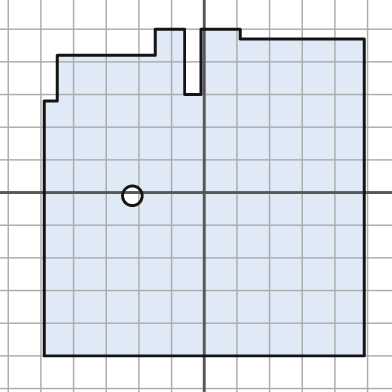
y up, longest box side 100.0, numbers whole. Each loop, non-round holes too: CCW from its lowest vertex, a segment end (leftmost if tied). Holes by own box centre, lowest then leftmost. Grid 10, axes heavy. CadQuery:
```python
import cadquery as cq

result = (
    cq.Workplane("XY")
    .moveTo(-49.0, -50.0)
    .lineTo(49.0, -50.0)
    .lineTo(49.0, 47.0)
    .lineTo(11.0, 47.0)
    .lineTo(11.0, 50.0)
    .lineTo(-1.0, 50.0)
    .lineTo(-1.0, 30.0)
    .lineTo(-6.0, 30.0)
    .lineTo(-6.0, 50.0)
    .lineTo(-15.0, 50.0)
    .lineTo(-15.0, 42.0)
    .lineTo(-45.0, 42.0)
    .lineTo(-45.0, 28.0)
    .lineTo(-49.0, 28.0)
    .close()
    .moveTo(-22.0, -1.0)
    .circle(3.0)
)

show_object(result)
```